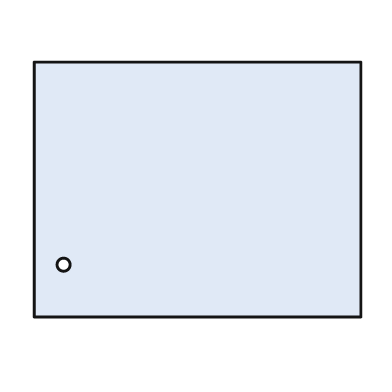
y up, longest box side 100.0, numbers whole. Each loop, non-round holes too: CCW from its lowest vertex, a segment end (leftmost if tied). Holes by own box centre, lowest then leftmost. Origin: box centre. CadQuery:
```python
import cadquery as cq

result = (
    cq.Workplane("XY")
    .moveTo(-50.0, -39.0)
    .lineTo(50.0, -39.0)
    .lineTo(50.0, 39.0)
    .lineTo(-50.0, 39.0)
    .close()
    .moveTo(-41.0, -23.0)
    .circle(2.0)
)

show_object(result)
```